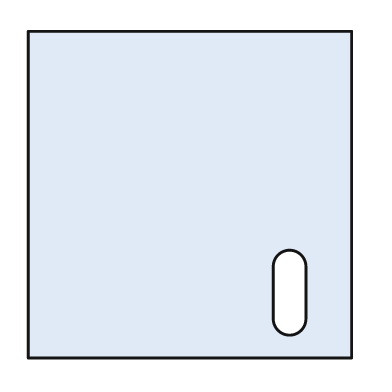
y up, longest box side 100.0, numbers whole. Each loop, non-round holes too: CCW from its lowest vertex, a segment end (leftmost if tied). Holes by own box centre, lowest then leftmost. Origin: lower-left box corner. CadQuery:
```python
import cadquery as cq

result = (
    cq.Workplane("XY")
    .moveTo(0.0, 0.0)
    .lineTo(99.0, 0.0)
    .lineTo(99.0, 100.0)
    .lineTo(0.0, 100.0)
    .close()
    .moveTo(75.0, 12.0)
    .threePointArc((80.0, 7.0), (85.0, 12.0))
    .lineTo(85.0, 28.0)
    .threePointArc((80.0, 33.0), (75.0, 28.0))
    .close()
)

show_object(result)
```